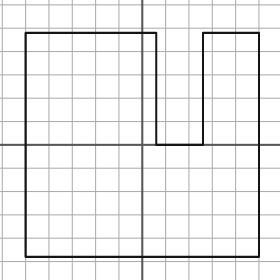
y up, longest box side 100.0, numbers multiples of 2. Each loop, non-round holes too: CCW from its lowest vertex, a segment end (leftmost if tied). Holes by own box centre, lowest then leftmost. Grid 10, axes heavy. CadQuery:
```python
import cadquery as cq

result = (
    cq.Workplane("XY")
    .moveTo(-50.0, -48.0)
    .lineTo(50.0, -48.0)
    .lineTo(50.0, 48.0)
    .lineTo(26.0, 48.0)
    .lineTo(26.0, 0.0)
    .lineTo(6.0, 0.0)
    .lineTo(6.0, 48.0)
    .lineTo(-50.0, 48.0)
    .close()
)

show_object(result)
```